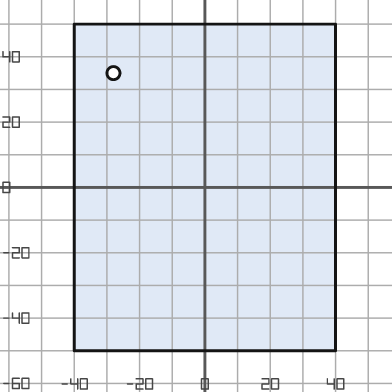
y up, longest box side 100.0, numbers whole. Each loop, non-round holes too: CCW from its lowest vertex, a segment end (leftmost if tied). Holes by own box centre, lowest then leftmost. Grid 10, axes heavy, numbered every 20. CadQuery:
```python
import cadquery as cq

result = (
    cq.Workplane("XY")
    .moveTo(-40.0, -50.0)
    .lineTo(40.0, -50.0)
    .lineTo(40.0, 50.0)
    .lineTo(-40.0, 50.0)
    .close()
    .moveTo(-28.0, 35.0)
    .circle(2.0)
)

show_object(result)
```